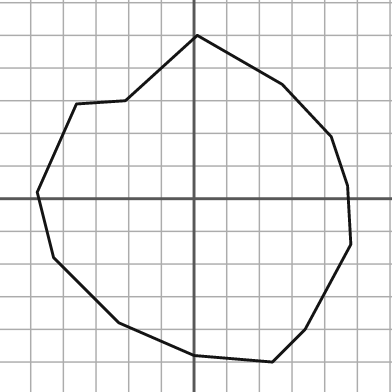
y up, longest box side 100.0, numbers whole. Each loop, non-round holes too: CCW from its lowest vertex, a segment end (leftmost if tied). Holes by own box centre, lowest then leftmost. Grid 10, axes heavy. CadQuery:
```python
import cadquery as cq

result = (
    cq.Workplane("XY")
    .moveTo(24.0, -50.0)
    .lineTo(34.0, -40.0)
    .lineTo(48.0, -14.0)
    .lineTo(47.0, 4.0)
    .lineTo(42.0, 19.0)
    .lineTo(27.0, 35.0)
    .lineTo(1.0, 50.0)
    .lineTo(-21.0, 30.0)
    .lineTo(-36.0, 29.0)
    .lineTo(-48.0, 2.0)
    .lineTo(-43.0, -18.0)
    .lineTo(-23.0, -38.0)
    .lineTo(0.0, -48.0)
    .close()
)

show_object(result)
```